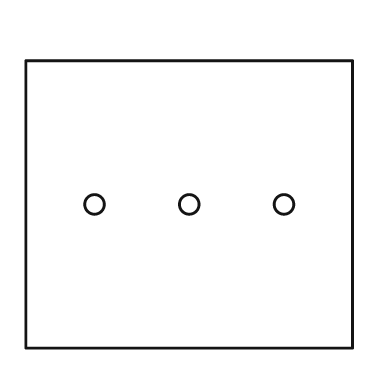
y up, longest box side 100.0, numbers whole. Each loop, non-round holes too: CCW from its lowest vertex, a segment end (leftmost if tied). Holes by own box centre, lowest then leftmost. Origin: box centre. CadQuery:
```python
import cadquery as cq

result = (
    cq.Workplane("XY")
    .moveTo(-50.0, -44.0)
    .lineTo(50.0, -44.0)
    .lineTo(50.0, 44.0)
    .lineTo(-50.0, 44.0)
    .close()
    .moveTo(-29.0, 0.0)
    .circle(3.0)
    .moveTo(0.0, 0.0)
    .circle(3.0)
    .moveTo(29.0, 0.0)
    .circle(3.0)
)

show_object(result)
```